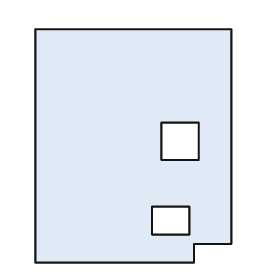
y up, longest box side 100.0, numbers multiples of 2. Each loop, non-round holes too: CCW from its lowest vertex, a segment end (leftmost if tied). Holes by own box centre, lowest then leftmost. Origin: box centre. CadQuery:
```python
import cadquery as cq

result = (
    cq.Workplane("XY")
    .moveTo(-42.0, -50.0)
    .lineTo(26.0, -50.0)
    .lineTo(26.0, -42.0)
    .lineTo(42.0, -42.0)
    .lineTo(42.0, 50.0)
    .lineTo(-42.0, 50.0)
    .close()
    .moveTo(8.0, -38.0)
    .lineTo(24.0, -38.0)
    .lineTo(24.0, -26.0)
    .lineTo(8.0, -26.0)
    .close()
    .moveTo(12.0, -6.0)
    .lineTo(28.0, -6.0)
    .lineTo(28.0, 10.0)
    .lineTo(12.0, 10.0)
    .close()
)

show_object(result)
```